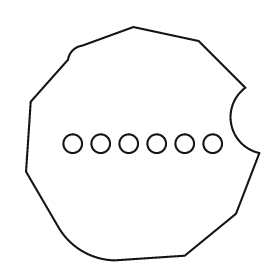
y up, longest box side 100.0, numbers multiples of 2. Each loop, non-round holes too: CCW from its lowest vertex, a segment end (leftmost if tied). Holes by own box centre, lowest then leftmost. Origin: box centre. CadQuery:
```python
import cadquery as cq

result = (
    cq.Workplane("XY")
    .moveTo(-12.0, -50.0)
    .lineTo(18.0, -48.0)
    .lineTo(40.0, -30.0)
    .lineTo(50.0, -4.0)
    .threePointArc((38.0, 8.0), (44.0, 24.0))
    .lineTo(24.0, 44.0)
    .lineTo(-4.0, 50.0)
    .lineTo(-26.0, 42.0)
    .threePointArc((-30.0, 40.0), (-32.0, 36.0))
    .lineTo(-48.0, 18.0)
    .lineTo(-50.0, -12.0)
    .lineTo(-36.0, -36.0)
    .threePointArc((-26.0, -46.0), (-12.0, -50.0))
    .close()
    .moveTo(-30.0, 0.0)
    .circle(4.0)
    .moveTo(-18.0, 0.0)
    .circle(4.0)
    .moveTo(-6.0, 0.0)
    .circle(4.0)
    .moveTo(6.0, 0.0)
    .circle(4.0)
    .moveTo(18.0, 0.0)
    .circle(4.0)
    .moveTo(30.0, 0.0)
    .circle(4.0)
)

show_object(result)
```